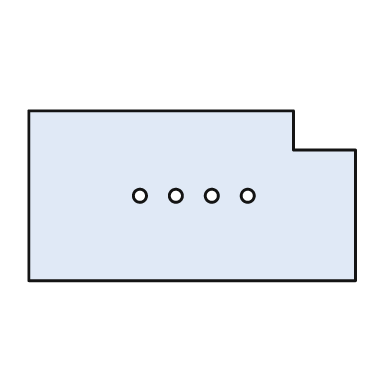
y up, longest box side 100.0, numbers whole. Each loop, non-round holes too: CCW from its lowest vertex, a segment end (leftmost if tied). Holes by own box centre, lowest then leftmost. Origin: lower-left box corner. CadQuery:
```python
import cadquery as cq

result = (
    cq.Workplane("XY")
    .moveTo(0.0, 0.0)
    .lineTo(100.0, 0.0)
    .lineTo(100.0, 40.0)
    .lineTo(81.0, 40.0)
    .lineTo(81.0, 52.0)
    .lineTo(0.0, 52.0)
    .close()
    .moveTo(34.0, 26.0)
    .circle(2.0)
    .moveTo(45.0, 26.0)
    .circle(2.0)
    .moveTo(56.0, 26.0)
    .circle(2.0)
    .moveTo(67.0, 26.0)
    .circle(2.0)
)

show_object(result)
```